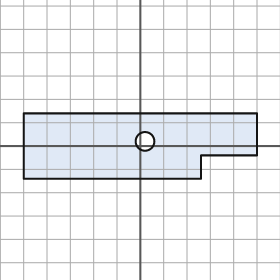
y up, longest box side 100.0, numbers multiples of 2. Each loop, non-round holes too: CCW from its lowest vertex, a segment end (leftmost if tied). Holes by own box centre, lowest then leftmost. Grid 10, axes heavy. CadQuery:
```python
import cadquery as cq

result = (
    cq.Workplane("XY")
    .moveTo(-50.0, -14.0)
    .lineTo(26.0, -14.0)
    .lineTo(26.0, -4.0)
    .lineTo(50.0, -4.0)
    .lineTo(50.0, 14.0)
    .lineTo(-50.0, 14.0)
    .close()
    .moveTo(2.0, 2.0)
    .circle(4.0)
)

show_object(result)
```